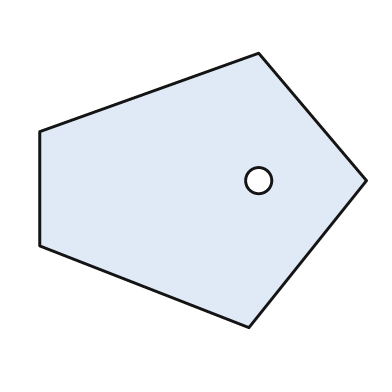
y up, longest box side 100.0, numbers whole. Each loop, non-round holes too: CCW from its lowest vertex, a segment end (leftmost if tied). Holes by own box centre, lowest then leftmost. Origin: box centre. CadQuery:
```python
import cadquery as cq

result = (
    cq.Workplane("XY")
    .moveTo(14.0, -42.0)
    .lineTo(50.0, 3.0)
    .lineTo(17.0, 42.0)
    .lineTo(-50.0, 18.0)
    .lineTo(-50.0, -17.0)
    .close()
    .moveTo(17.0, 3.0)
    .circle(4.0)
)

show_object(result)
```